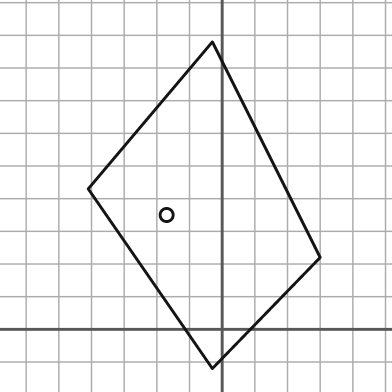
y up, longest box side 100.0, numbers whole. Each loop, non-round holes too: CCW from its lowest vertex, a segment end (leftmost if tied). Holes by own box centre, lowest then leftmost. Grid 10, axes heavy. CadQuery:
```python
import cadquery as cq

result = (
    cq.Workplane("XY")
    .moveTo(-3.0, -12.0)
    .lineTo(30.0, 22.0)
    .lineTo(-3.0, 88.0)
    .lineTo(-41.0, 43.0)
    .close()
    .moveTo(-17.0, 35.0)
    .circle(2.0)
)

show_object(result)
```